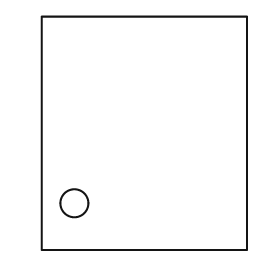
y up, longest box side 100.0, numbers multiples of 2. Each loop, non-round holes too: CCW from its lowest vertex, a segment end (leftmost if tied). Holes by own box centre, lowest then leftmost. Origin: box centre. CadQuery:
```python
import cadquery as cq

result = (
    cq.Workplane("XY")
    .moveTo(-44.0, -50.0)
    .lineTo(44.0, -50.0)
    .lineTo(44.0, 50.0)
    .lineTo(-44.0, 50.0)
    .close()
    .moveTo(-30.0, -30.0)
    .circle(6.0)
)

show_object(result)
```